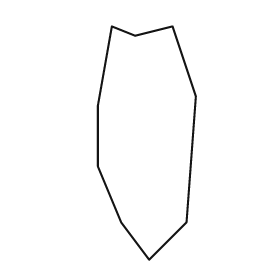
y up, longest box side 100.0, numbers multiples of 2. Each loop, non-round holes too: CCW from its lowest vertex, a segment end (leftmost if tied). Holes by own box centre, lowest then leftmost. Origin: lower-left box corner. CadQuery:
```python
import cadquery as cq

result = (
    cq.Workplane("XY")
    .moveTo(22.0, 0.0)
    .lineTo(38.0, 16.0)
    .lineTo(42.0, 70.0)
    .lineTo(32.0, 100.0)
    .lineTo(16.0, 96.0)
    .lineTo(6.0, 100.0)
    .lineTo(0.0, 66.0)
    .lineTo(0.0, 40.0)
    .lineTo(10.0, 16.0)
    .close()
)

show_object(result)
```